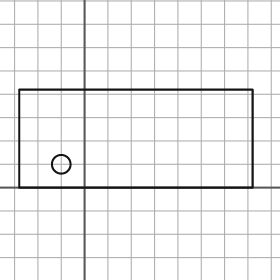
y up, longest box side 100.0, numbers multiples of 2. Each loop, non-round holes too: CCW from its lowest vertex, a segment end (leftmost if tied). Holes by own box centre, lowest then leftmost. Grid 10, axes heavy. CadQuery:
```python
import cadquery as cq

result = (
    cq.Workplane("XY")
    .moveTo(-28.0, 0.0)
    .lineTo(72.0, 0.0)
    .lineTo(72.0, 42.0)
    .lineTo(-28.0, 42.0)
    .close()
    .moveTo(-10.0, 10.0)
    .circle(4.0)
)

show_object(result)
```